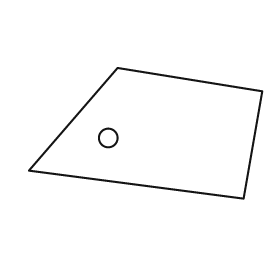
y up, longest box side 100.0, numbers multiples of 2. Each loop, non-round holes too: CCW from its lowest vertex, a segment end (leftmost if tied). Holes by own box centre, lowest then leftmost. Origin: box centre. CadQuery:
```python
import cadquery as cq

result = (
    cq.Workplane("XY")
    .moveTo(42.0, -28.0)
    .lineTo(50.0, 18.0)
    .lineTo(-12.0, 28.0)
    .lineTo(-50.0, -16.0)
    .close()
    .moveTo(-16.0, -2.0)
    .circle(4.0)
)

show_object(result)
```